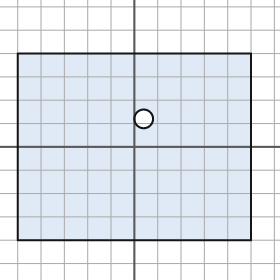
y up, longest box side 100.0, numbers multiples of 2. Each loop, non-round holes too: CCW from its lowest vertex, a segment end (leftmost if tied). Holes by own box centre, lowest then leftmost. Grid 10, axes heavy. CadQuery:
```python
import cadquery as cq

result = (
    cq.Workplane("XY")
    .moveTo(-50.0, -40.0)
    .lineTo(50.0, -40.0)
    .lineTo(50.0, 40.0)
    .lineTo(-50.0, 40.0)
    .close()
    .moveTo(4.0, 12.0)
    .circle(4.0)
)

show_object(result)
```